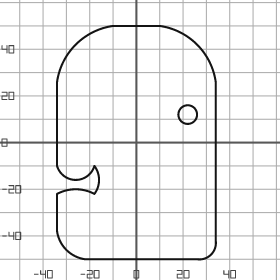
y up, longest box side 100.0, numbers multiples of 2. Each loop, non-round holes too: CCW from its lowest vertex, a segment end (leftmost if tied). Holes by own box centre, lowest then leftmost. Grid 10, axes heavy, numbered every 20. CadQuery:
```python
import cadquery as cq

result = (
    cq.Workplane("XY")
    .moveTo(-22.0, -50.0)
    .lineTo(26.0, -50.0)
    .threePointArc((32.0, -48.0), (34.0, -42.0))
    .lineTo(34.0, 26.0)
    .threePointArc((26.0, 42.0), (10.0, 50.0))
    .lineTo(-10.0, 50.0)
    .threePointArc((-26.0, 42.0), (-34.0, 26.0))
    .lineTo(-34.0, -10.0)
    .threePointArc((-26.0, -16.0), (-18.0, -10.0))
    .threePointArc((-16.0, -16.0), (-18.0, -22.0))
    .threePointArc((-26.0, -20.0), (-34.0, -22.0))
    .lineTo(-34.0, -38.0)
    .threePointArc((-30.0, -46.0), (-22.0, -50.0))
    .close()
    .moveTo(22.0, 12.0)
    .circle(4.0)
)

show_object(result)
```